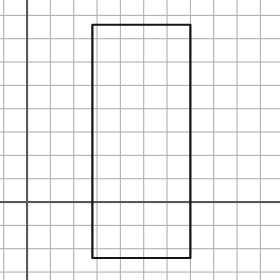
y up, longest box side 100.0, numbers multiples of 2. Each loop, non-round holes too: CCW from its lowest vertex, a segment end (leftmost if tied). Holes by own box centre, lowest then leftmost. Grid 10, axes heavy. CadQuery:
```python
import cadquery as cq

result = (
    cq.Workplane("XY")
    .moveTo(28.0, -24.0)
    .lineTo(70.0, -24.0)
    .lineTo(70.0, 76.0)
    .lineTo(28.0, 76.0)
    .close()
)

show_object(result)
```